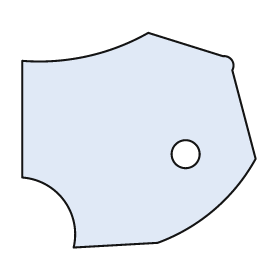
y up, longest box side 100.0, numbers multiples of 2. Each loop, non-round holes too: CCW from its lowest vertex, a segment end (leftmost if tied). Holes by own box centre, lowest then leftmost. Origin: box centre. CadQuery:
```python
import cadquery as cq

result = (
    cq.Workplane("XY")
    .moveTo(-28.0, -46.0)
    .lineTo(8.0, -44.0)
    .threePointArc((32.0, -30.0), (50.0, -8.0))
    .lineTo(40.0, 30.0)
    .threePointArc((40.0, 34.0), (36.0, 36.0))
    .lineTo(4.0, 46.0)
    .threePointArc((-22.0, 36.0), (-50.0, 34.0))
    .lineTo(-50.0, -16.0)
    .threePointArc((-32.0, -26.0), (-28.0, -46.0))
    .close()
    .moveTo(20.0, -6.0)
    .circle(6.0)
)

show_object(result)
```